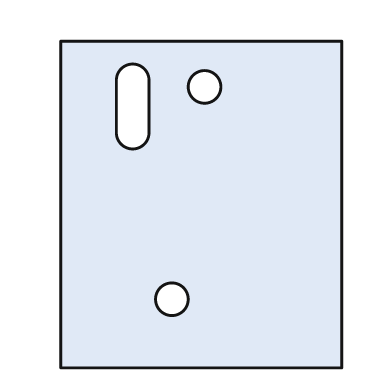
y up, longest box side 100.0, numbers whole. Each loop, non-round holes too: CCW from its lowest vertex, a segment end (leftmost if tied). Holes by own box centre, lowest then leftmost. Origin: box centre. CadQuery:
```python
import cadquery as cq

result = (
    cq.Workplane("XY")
    .moveTo(-43.0, -50.0)
    .lineTo(43.0, -50.0)
    .lineTo(43.0, 50.0)
    .lineTo(-43.0, 50.0)
    .close()
    .moveTo(-9.0, -29.0)
    .circle(5.0)
    .moveTo(-26.0, 22.0)
    .threePointArc((-21.0, 17.0), (-16.0, 22.0))
    .lineTo(-16.0, 38.0)
    .threePointArc((-21.0, 43.0), (-26.0, 38.0))
    .close()
    .moveTo(1.0, 36.0)
    .circle(5.0)
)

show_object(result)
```